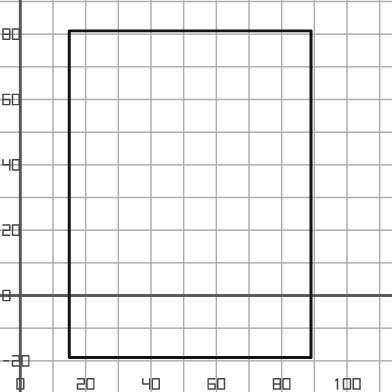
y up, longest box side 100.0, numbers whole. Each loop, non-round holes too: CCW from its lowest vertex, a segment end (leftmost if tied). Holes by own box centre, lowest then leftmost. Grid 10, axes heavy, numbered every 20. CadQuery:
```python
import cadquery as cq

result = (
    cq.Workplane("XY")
    .moveTo(15.0, -19.0)
    .lineTo(89.0, -19.0)
    .lineTo(89.0, 81.0)
    .lineTo(15.0, 81.0)
    .close()
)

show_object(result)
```